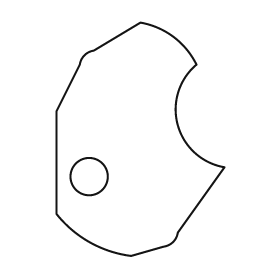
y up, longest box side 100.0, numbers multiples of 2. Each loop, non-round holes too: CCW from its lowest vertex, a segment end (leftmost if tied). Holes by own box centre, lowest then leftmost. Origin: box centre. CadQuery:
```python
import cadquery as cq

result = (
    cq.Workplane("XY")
    .moveTo(-4.0, -50.0)
    .lineTo(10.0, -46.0)
    .threePointArc((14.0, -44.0), (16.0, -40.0))
    .lineTo(36.0, -12.0)
    .threePointArc((16.0, 6.0), (24.0, 32.0))
    .threePointArc((14.0, 44.0), (0.0, 50.0))
    .lineTo(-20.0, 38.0)
    .threePointArc((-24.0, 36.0), (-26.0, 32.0))
    .lineTo(-36.0, 12.0)
    .lineTo(-36.0, -32.0)
    .threePointArc((-22.0, -44.0), (-4.0, -50.0))
    .close()
    .moveTo(-22.0, -16.0)
    .circle(8.0)
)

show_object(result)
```